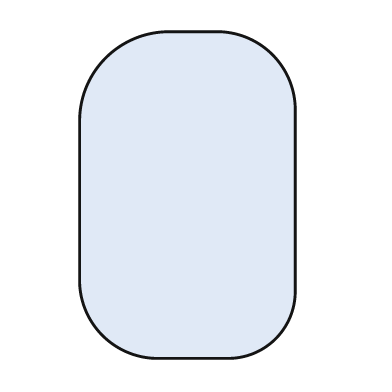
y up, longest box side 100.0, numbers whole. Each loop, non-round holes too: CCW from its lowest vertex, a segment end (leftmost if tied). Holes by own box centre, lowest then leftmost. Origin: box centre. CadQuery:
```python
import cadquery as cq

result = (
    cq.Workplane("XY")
    .moveTo(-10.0, -50.0)
    .lineTo(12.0, -50.0)
    .threePointArc((27.0, -44.0), (33.0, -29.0))
    .lineTo(33.0, 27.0)
    .threePointArc((26.0, 43.0), (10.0, 50.0))
    .lineTo(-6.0, 50.0)
    .threePointArc((-25.0, 42.0), (-33.0, 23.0))
    .lineTo(-33.0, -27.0)
    .threePointArc((-26.0, -43.0), (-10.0, -50.0))
    .close()
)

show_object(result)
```